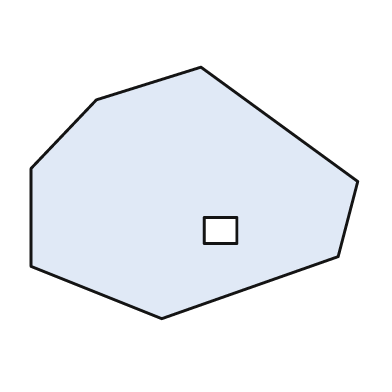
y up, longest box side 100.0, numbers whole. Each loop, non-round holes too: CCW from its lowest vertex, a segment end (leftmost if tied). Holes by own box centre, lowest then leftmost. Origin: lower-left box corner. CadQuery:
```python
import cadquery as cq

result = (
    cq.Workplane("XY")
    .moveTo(40.0, 0.0)
    .lineTo(94.0, 19.0)
    .lineTo(100.0, 42.0)
    .lineTo(52.0, 77.0)
    .lineTo(20.0, 67.0)
    .lineTo(0.0, 46.0)
    .lineTo(0.0, 16.0)
    .close()
    .moveTo(53.0, 23.0)
    .lineTo(63.0, 23.0)
    .lineTo(63.0, 31.0)
    .lineTo(53.0, 31.0)
    .close()
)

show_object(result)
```